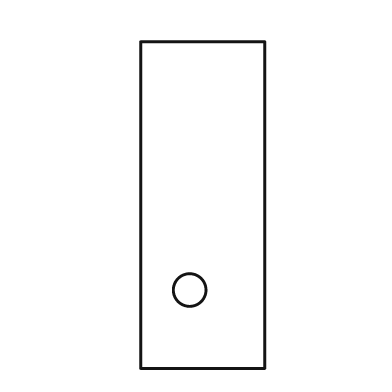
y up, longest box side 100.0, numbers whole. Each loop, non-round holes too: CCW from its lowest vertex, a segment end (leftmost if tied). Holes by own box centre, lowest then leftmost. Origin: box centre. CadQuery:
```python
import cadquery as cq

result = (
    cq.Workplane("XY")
    .moveTo(-19.0, -50.0)
    .lineTo(19.0, -50.0)
    .lineTo(19.0, 50.0)
    .lineTo(-19.0, 50.0)
    .close()
    .moveTo(-4.0, -26.0)
    .circle(5.0)
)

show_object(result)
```